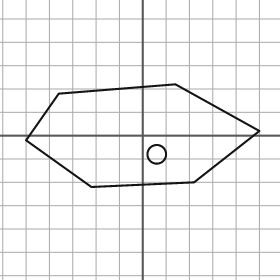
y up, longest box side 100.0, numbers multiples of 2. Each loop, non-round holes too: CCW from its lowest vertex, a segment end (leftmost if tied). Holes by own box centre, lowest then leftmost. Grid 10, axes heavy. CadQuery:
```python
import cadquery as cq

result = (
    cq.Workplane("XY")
    .moveTo(-22.0, -22.0)
    .lineTo(22.0, -20.0)
    .lineTo(50.0, 2.0)
    .lineTo(14.0, 22.0)
    .lineTo(-36.0, 18.0)
    .lineTo(-50.0, -2.0)
    .close()
    .moveTo(6.0, -8.0)
    .circle(4.0)
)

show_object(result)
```